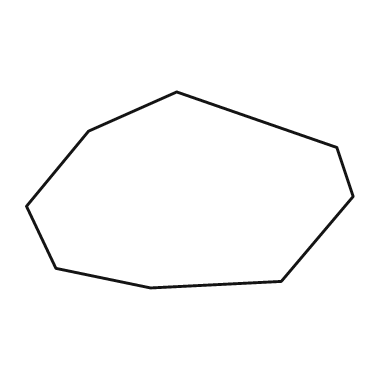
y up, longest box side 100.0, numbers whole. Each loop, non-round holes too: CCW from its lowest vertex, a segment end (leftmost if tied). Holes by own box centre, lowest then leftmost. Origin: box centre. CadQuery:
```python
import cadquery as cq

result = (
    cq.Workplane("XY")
    .moveTo(-12.0, -30.0)
    .lineTo(28.0, -28.0)
    .lineTo(50.0, -2.0)
    .lineTo(45.0, 13.0)
    .lineTo(-4.0, 30.0)
    .lineTo(-31.0, 18.0)
    .lineTo(-50.0, -5.0)
    .lineTo(-41.0, -24.0)
    .close()
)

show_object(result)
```